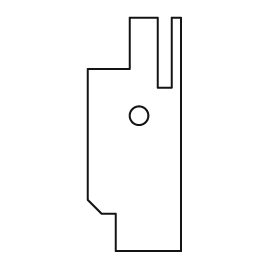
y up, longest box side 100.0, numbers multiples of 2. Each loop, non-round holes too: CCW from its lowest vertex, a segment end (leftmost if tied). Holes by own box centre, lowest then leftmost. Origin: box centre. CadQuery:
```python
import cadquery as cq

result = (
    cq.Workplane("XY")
    .moveTo(-8.0, -50.0)
    .lineTo(20.0, -50.0)
    .lineTo(20.0, 50.0)
    .lineTo(16.0, 50.0)
    .lineTo(16.0, 20.0)
    .lineTo(10.0, 20.0)
    .lineTo(10.0, 50.0)
    .lineTo(-2.0, 50.0)
    .lineTo(-2.0, 28.0)
    .lineTo(-20.0, 28.0)
    .lineTo(-20.0, -28.0)
    .lineTo(-14.0, -34.0)
    .lineTo(-8.0, -34.0)
    .close()
    .moveTo(2.0, 8.0)
    .circle(4.0)
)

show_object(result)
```